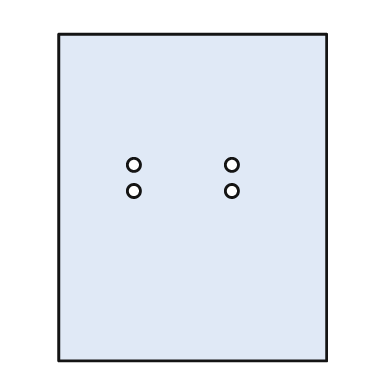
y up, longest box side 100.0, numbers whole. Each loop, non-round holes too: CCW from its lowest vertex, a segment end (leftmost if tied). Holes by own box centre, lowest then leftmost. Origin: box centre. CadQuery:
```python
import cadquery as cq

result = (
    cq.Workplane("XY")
    .moveTo(-41.0, -50.0)
    .lineTo(41.0, -50.0)
    .lineTo(41.0, 50.0)
    .lineTo(-41.0, 50.0)
    .close()
    .moveTo(-18.0, 2.0)
    .circle(2.0)
    .moveTo(12.0, 2.0)
    .circle(2.0)
    .moveTo(-18.0, 10.0)
    .circle(2.0)
    .moveTo(12.0, 10.0)
    .circle(2.0)
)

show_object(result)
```